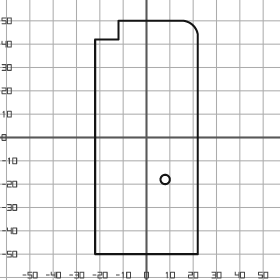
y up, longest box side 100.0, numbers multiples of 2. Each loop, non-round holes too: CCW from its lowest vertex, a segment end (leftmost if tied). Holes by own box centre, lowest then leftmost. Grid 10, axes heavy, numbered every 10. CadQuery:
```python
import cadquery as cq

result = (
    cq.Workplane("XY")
    .moveTo(-22.0, -50.0)
    .lineTo(22.0, -50.0)
    .lineTo(22.0, 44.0)
    .threePointArc((20.0, 48.0), (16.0, 50.0))
    .lineTo(-12.0, 50.0)
    .lineTo(-12.0, 42.0)
    .lineTo(-22.0, 42.0)
    .close()
    .moveTo(8.0, -18.0)
    .circle(2.0)
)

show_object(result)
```